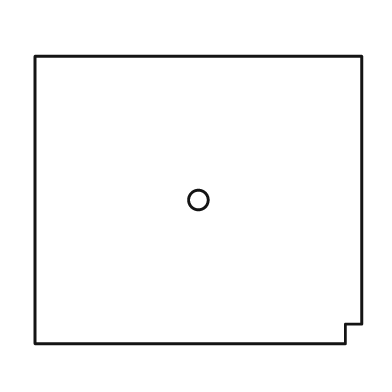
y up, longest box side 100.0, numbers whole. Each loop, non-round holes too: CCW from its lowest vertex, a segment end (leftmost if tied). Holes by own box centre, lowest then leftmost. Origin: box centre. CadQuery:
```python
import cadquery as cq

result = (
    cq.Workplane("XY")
    .moveTo(-50.0, -44.0)
    .lineTo(45.0, -44.0)
    .lineTo(45.0, -38.0)
    .lineTo(50.0, -38.0)
    .lineTo(50.0, 44.0)
    .lineTo(-50.0, 44.0)
    .close()
    .moveTo(0.0, 0.0)
    .circle(3.0)
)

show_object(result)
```